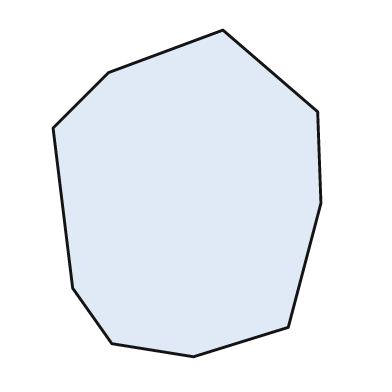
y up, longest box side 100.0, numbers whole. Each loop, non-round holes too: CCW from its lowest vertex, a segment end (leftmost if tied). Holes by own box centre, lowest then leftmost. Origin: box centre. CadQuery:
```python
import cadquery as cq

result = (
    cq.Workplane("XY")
    .moveTo(2.0, -50.0)
    .lineTo(31.0, -41.0)
    .lineTo(41.0, -3.0)
    .lineTo(40.0, 25.0)
    .lineTo(11.0, 50.0)
    .lineTo(-24.0, 37.0)
    .lineTo(-41.0, 20.0)
    .lineTo(-35.0, -29.0)
    .lineTo(-23.0, -46.0)
    .close()
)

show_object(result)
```